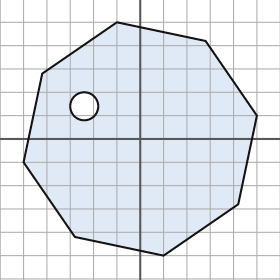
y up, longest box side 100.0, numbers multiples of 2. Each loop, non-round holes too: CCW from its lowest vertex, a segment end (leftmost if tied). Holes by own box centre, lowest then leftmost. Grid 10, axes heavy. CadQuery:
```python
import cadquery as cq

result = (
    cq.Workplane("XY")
    .moveTo(10.0, -50.0)
    .lineTo(42.0, -28.0)
    .lineTo(50.0, 10.0)
    .lineTo(28.0, 42.0)
    .lineTo(-10.0, 50.0)
    .lineTo(-42.0, 28.0)
    .lineTo(-50.0, -10.0)
    .lineTo(-28.0, -42.0)
    .close()
    .moveTo(-24.0, 14.0)
    .circle(6.0)
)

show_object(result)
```